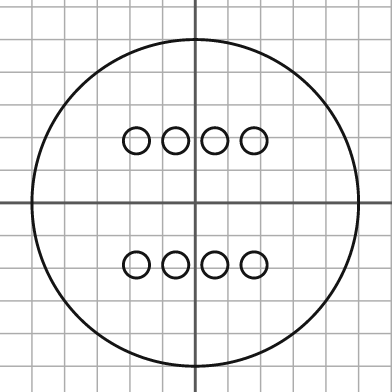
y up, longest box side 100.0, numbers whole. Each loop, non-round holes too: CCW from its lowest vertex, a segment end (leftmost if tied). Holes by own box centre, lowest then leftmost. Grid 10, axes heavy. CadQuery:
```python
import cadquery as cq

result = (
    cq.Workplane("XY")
    .moveTo(0.0, 0.0)
    .circle(50.0)
    .moveTo(-18.0, -19.0)
    .circle(4.0)
    .moveTo(-6.0, -19.0)
    .circle(4.0)
    .moveTo(6.0, -19.0)
    .circle(4.0)
    .moveTo(18.0, -19.0)
    .circle(4.0)
    .moveTo(-18.0, 19.0)
    .circle(4.0)
    .moveTo(-6.0, 19.0)
    .circle(4.0)
    .moveTo(6.0, 19.0)
    .circle(4.0)
    .moveTo(18.0, 19.0)
    .circle(4.0)
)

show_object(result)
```